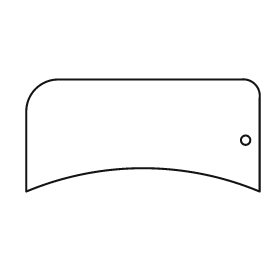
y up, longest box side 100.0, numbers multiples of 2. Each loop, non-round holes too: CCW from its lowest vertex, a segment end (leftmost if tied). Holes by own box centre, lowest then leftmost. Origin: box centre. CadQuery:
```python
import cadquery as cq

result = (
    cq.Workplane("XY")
    .moveTo(-50.0, -24.0)
    .threePointArc((0.0, -14.0), (50.0, -24.0))
    .lineTo(50.0, 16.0)
    .threePointArc((48.0, 22.0), (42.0, 24.0))
    .lineTo(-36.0, 24.0)
    .threePointArc((-46.0, 20.0), (-50.0, 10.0))
    .close()
    .moveTo(44.0, -2.0)
    .circle(2.0)
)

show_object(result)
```